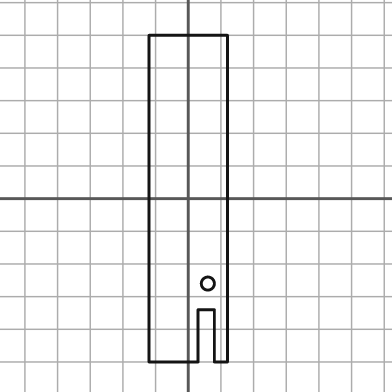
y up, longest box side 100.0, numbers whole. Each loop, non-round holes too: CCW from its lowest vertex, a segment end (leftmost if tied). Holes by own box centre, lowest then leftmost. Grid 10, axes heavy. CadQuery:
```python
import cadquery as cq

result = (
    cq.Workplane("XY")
    .moveTo(-12.0, -50.0)
    .lineTo(3.0, -50.0)
    .lineTo(3.0, -34.0)
    .lineTo(8.0, -34.0)
    .lineTo(8.0, -50.0)
    .lineTo(12.0, -50.0)
    .lineTo(12.0, 50.0)
    .lineTo(-12.0, 50.0)
    .close()
    .moveTo(6.0, -26.0)
    .circle(2.0)
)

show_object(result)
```